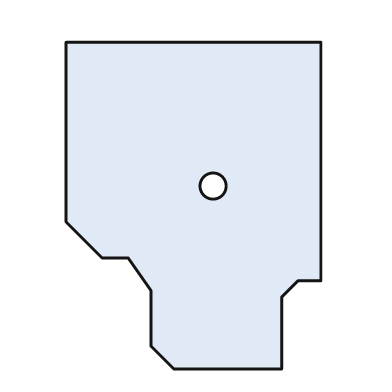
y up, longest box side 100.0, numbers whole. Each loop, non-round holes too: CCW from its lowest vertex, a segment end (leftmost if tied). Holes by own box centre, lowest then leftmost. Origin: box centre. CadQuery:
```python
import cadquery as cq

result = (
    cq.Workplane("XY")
    .moveTo(-6.0, -50.0)
    .lineTo(27.0, -50.0)
    .lineTo(27.0, -28.0)
    .lineTo(32.0, -23.0)
    .lineTo(39.0, -23.0)
    .lineTo(39.0, 50.0)
    .lineTo(-39.0, 50.0)
    .lineTo(-39.0, -5.0)
    .lineTo(-28.0, -16.0)
    .lineTo(-20.0, -16.0)
    .lineTo(-13.0, -26.0)
    .lineTo(-13.0, -43.0)
    .close()
    .moveTo(6.0, 6.0)
    .circle(4.0)
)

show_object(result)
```